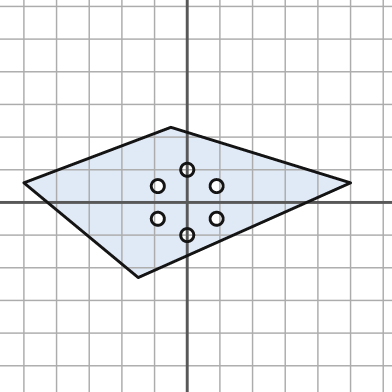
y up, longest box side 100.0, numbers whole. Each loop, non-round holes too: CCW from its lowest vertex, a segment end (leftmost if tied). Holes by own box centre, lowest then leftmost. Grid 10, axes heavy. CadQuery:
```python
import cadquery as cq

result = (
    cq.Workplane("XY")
    .moveTo(-15.0, -23.0)
    .lineTo(50.0, 6.0)
    .lineTo(-5.0, 23.0)
    .lineTo(-50.0, 6.0)
    .close()
    .moveTo(0.0, -10.0)
    .circle(2.0)
    .moveTo(-9.0, -5.0)
    .circle(2.0)
    .moveTo(9.0, -5.0)
    .circle(2.0)
    .moveTo(-9.0, 5.0)
    .circle(2.0)
    .moveTo(9.0, 5.0)
    .circle(2.0)
    .moveTo(0.0, 10.0)
    .circle(2.0)
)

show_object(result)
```